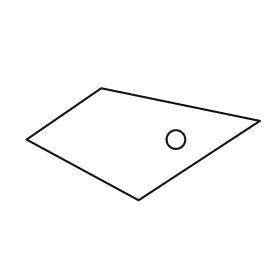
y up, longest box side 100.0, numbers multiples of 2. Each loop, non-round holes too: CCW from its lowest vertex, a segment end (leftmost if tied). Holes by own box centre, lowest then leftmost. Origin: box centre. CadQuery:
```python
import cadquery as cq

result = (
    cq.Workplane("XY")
    .moveTo(-2.0, -24.0)
    .lineTo(50.0, 10.0)
    .lineTo(-18.0, 24.0)
    .lineTo(-50.0, 2.0)
    .close()
    .moveTo(14.0, 2.0)
    .circle(4.0)
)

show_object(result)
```